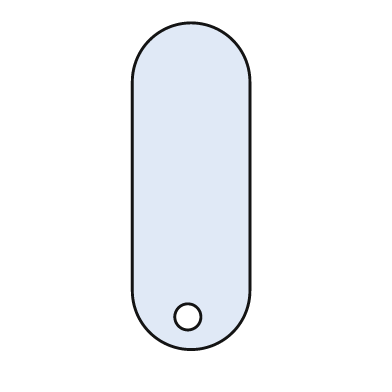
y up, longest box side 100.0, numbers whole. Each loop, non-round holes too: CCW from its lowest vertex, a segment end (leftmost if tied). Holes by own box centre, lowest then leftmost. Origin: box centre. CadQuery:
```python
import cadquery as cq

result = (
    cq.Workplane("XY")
    .moveTo(-18.0, -32.0)
    .threePointArc((0.0, -50.0), (18.0, -32.0))
    .lineTo(18.0, 32.0)
    .threePointArc((0.0, 50.0), (-18.0, 32.0))
    .close()
    .moveTo(-1.0, -40.0)
    .circle(4.0)
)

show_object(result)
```